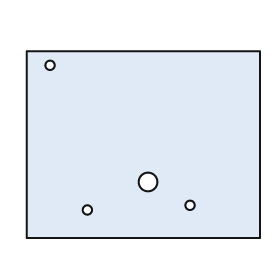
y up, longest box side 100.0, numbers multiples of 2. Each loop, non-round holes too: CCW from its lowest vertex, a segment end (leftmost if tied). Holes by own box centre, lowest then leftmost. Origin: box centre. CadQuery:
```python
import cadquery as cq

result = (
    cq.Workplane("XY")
    .moveTo(-50.0, -40.0)
    .lineTo(50.0, -40.0)
    .lineTo(50.0, 40.0)
    .lineTo(-50.0, 40.0)
    .close()
    .moveTo(-24.0, -28.0)
    .circle(2.0)
    .moveTo(20.0, -26.0)
    .circle(2.0)
    .moveTo(2.0, -16.0)
    .circle(4.0)
    .moveTo(-40.0, 34.0)
    .circle(2.0)
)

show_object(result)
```